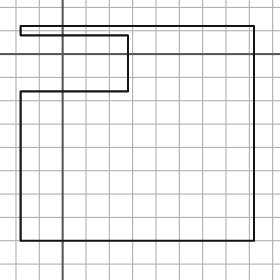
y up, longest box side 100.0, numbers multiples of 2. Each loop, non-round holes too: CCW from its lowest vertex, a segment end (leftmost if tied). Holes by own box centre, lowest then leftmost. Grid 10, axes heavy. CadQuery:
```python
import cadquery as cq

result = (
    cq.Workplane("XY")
    .moveTo(-18.0, -80.0)
    .lineTo(82.0, -80.0)
    .lineTo(82.0, 12.0)
    .lineTo(-18.0, 12.0)
    .lineTo(-18.0, 8.0)
    .lineTo(28.0, 8.0)
    .lineTo(28.0, -16.0)
    .lineTo(-18.0, -16.0)
    .close()
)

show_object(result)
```